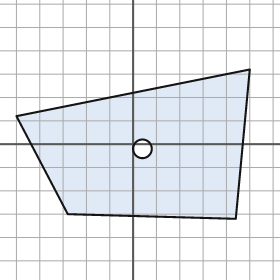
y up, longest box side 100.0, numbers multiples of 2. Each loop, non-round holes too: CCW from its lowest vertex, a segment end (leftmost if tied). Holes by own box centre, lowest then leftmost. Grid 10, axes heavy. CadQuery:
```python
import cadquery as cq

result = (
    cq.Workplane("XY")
    .moveTo(44.0, -32.0)
    .lineTo(50.0, 32.0)
    .lineTo(-50.0, 12.0)
    .lineTo(-28.0, -30.0)
    .close()
    .moveTo(4.0, -2.0)
    .circle(4.0)
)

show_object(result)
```